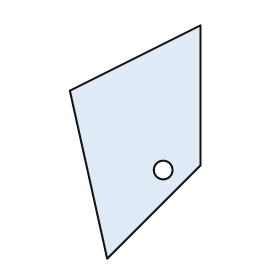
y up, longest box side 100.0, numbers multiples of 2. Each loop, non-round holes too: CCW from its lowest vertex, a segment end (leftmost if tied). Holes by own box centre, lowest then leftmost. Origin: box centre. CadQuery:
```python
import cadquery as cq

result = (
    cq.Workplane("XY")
    .moveTo(-12.0, -50.0)
    .lineTo(28.0, -10.0)
    .lineTo(28.0, 50.0)
    .lineTo(-28.0, 22.0)
    .close()
    .moveTo(12.0, -12.0)
    .circle(4.0)
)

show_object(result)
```